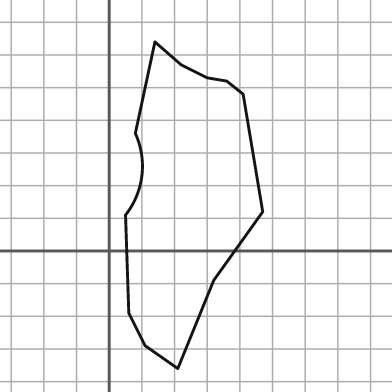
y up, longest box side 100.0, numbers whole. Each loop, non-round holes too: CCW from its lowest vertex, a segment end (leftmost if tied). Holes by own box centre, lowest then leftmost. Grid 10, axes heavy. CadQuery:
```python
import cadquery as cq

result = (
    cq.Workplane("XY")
    .moveTo(21.0, -36.0)
    .lineTo(32.0, -9.0)
    .lineTo(47.0, 12.0)
    .lineTo(41.0, 48.0)
    .lineTo(36.0, 52.0)
    .lineTo(30.0, 53.0)
    .lineTo(22.0, 57.0)
    .lineTo(14.0, 64.0)
    .lineTo(8.0, 36.0)
    .threePointArc((10.0, 23.0), (5.0, 11.0))
    .lineTo(6.0, -19.0)
    .lineTo(11.0, -29.0)
    .close()
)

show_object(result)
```